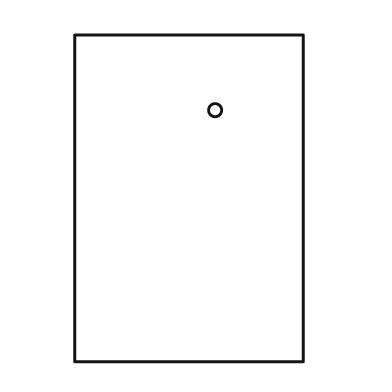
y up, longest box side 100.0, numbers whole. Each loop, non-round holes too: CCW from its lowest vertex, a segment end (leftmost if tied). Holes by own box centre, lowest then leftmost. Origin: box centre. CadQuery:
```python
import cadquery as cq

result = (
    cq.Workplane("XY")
    .moveTo(-35.0, -50.0)
    .lineTo(35.0, -50.0)
    .lineTo(35.0, 50.0)
    .lineTo(-35.0, 50.0)
    .close()
    .moveTo(8.0, 27.0)
    .circle(2.0)
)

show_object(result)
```